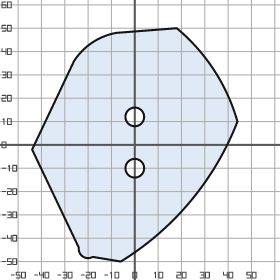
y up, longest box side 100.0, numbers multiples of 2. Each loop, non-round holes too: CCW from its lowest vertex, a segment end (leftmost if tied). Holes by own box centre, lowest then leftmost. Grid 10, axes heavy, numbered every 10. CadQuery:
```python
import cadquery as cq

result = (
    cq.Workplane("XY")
    .moveTo(-6.0, -50.0)
    .threePointArc((24.0, -24.0), (44.0, 10.0))
    .threePointArc((34.0, 32.0), (18.0, 50.0))
    .lineTo(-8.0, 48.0)
    .threePointArc((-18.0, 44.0), (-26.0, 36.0))
    .lineTo(-44.0, -2.0)
    .lineTo(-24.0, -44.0)
    .threePointArc((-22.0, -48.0), (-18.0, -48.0))
    .close()
    .moveTo(0.0, -10.0)
    .circle(4.0)
    .moveTo(0.0, 12.0)
    .circle(4.0)
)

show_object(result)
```